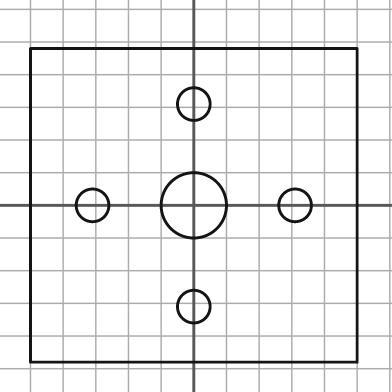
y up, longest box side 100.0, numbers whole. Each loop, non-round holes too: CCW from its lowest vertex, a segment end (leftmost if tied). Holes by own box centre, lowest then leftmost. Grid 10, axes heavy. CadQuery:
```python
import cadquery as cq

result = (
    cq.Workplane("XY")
    .moveTo(-50.0, -48.0)
    .lineTo(50.0, -48.0)
    .lineTo(50.0, 48.0)
    .lineTo(-50.0, 48.0)
    .close()
    .moveTo(0.0, -31.0)
    .circle(5.0)
    .moveTo(-31.0, 0.0)
    .circle(5.0)
    .moveTo(0.0, 0.0)
    .circle(10.0)
    .moveTo(31.0, 0.0)
    .circle(5.0)
    .moveTo(0.0, 31.0)
    .circle(5.0)
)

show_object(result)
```